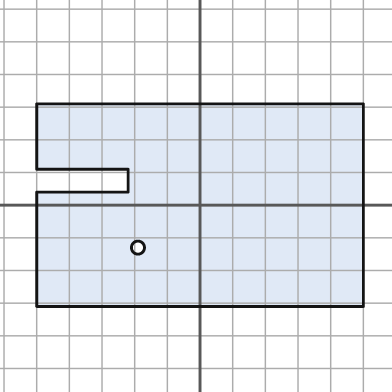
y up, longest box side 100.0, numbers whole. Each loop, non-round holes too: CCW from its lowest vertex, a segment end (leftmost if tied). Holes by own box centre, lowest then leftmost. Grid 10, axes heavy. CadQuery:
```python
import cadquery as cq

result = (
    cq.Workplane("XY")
    .moveTo(-50.0, -31.0)
    .lineTo(50.0, -31.0)
    .lineTo(50.0, 31.0)
    .lineTo(-50.0, 31.0)
    .lineTo(-50.0, 11.0)
    .lineTo(-22.0, 11.0)
    .lineTo(-22.0, 4.0)
    .lineTo(-50.0, 4.0)
    .close()
    .moveTo(-19.0, -13.0)
    .circle(2.0)
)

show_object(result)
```